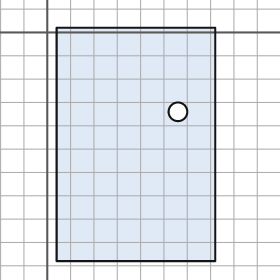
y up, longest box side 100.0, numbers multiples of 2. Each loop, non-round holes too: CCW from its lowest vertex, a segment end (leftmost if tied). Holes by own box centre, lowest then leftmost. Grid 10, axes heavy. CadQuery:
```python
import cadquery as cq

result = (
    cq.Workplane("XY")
    .moveTo(4.0, -98.0)
    .lineTo(72.0, -98.0)
    .lineTo(72.0, 2.0)
    .lineTo(4.0, 2.0)
    .close()
    .moveTo(56.0, -34.0)
    .circle(4.0)
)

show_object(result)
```